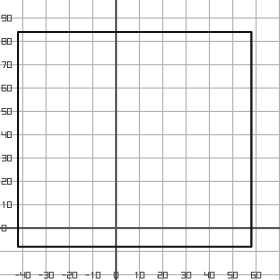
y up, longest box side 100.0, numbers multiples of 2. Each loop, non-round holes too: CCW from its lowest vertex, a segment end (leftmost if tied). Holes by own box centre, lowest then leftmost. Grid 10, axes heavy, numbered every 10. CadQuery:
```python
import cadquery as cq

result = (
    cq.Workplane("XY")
    .moveTo(-42.0, -8.0)
    .lineTo(58.0, -8.0)
    .lineTo(58.0, 84.0)
    .lineTo(-42.0, 84.0)
    .close()
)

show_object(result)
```